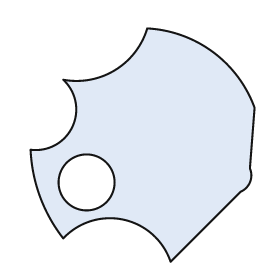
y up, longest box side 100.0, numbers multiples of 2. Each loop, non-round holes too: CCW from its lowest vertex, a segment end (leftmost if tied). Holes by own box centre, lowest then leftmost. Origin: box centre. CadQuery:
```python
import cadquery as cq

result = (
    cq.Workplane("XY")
    .moveTo(12.0, -50.0)
    .lineTo(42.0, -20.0)
    .threePointArc((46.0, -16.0), (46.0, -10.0))
    .lineTo(48.0, 16.0)
    .threePointArc((30.0, 40.0), (2.0, 50.0))
    .threePointArc((-12.0, 32.0), (-34.0, 28.0))
    .threePointArc((-30.0, 8.0), (-48.0, -2.0))
    .threePointArc((-44.0, -22.0), (-34.0, -40.0))
    .threePointArc((-8.0, -32.0), (12.0, -50.0))
    .close()
    .moveTo(-24.0, -16.0)
    .circle(12.0)
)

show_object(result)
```